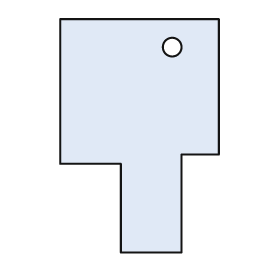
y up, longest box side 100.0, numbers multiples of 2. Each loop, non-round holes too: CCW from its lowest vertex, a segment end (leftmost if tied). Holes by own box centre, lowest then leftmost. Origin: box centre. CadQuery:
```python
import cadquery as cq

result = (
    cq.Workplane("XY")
    .moveTo(-8.0, -50.0)
    .lineTo(18.0, -50.0)
    .lineTo(18.0, -8.0)
    .lineTo(34.0, -8.0)
    .lineTo(34.0, 50.0)
    .lineTo(-34.0, 50.0)
    .lineTo(-34.0, -12.0)
    .lineTo(-8.0, -12.0)
    .close()
    .moveTo(14.0, 38.0)
    .circle(4.0)
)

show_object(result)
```